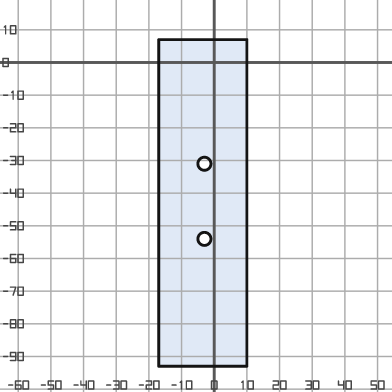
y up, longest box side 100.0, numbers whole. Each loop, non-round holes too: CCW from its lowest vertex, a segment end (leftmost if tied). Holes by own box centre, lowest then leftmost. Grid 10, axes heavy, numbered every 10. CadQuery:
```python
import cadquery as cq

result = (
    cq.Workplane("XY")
    .moveTo(-17.0, -93.0)
    .lineTo(10.0, -93.0)
    .lineTo(10.0, 7.0)
    .lineTo(-17.0, 7.0)
    .close()
    .moveTo(-3.0, -54.0)
    .circle(2.0)
    .moveTo(-3.0, -31.0)
    .circle(2.0)
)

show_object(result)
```